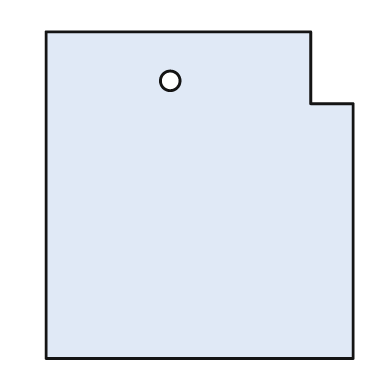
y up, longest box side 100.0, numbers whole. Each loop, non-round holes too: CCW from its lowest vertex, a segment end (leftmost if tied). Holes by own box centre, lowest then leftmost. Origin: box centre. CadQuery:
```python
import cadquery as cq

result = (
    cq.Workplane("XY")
    .moveTo(-47.0, -50.0)
    .lineTo(47.0, -50.0)
    .lineTo(47.0, 28.0)
    .lineTo(34.0, 28.0)
    .lineTo(34.0, 50.0)
    .lineTo(-47.0, 50.0)
    .close()
    .moveTo(-9.0, 35.0)
    .circle(3.0)
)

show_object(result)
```